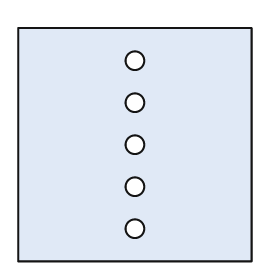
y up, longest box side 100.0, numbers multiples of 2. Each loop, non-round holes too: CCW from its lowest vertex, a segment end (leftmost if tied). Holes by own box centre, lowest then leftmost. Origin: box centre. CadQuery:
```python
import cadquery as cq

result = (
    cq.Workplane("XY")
    .moveTo(-50.0, -50.0)
    .lineTo(50.0, -50.0)
    .lineTo(50.0, 50.0)
    .lineTo(-50.0, 50.0)
    .close()
    .moveTo(0.0, -36.0)
    .circle(4.0)
    .moveTo(0.0, -18.0)
    .circle(4.0)
    .moveTo(0.0, 0.0)
    .circle(4.0)
    .moveTo(0.0, 18.0)
    .circle(4.0)
    .moveTo(0.0, 36.0)
    .circle(4.0)
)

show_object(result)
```